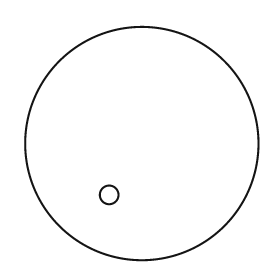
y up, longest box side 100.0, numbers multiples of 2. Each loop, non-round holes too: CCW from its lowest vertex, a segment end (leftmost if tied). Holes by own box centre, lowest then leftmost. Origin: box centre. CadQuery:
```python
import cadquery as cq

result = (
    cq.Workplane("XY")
    .moveTo(0.0, 0.0)
    .circle(50.0)
    .moveTo(-14.0, -22.0)
    .circle(4.0)
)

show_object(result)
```